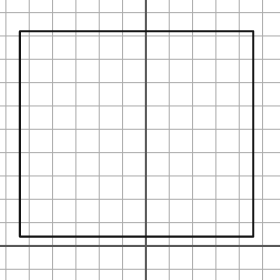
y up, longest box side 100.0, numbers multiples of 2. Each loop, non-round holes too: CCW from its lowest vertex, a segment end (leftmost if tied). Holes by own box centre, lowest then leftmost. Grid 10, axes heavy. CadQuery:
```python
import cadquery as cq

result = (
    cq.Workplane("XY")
    .moveTo(-54.0, 4.0)
    .lineTo(46.0, 4.0)
    .lineTo(46.0, 92.0)
    .lineTo(-54.0, 92.0)
    .close()
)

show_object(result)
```